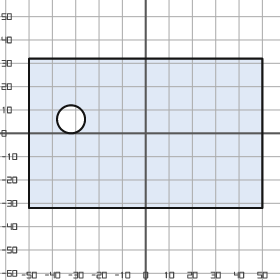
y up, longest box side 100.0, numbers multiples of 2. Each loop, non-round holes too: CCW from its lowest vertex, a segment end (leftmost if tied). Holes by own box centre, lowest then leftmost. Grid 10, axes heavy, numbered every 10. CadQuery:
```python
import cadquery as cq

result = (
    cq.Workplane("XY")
    .moveTo(-50.0, -32.0)
    .lineTo(50.0, -32.0)
    .lineTo(50.0, 32.0)
    .lineTo(-50.0, 32.0)
    .close()
    .moveTo(-32.0, 6.0)
    .circle(6.0)
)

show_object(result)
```